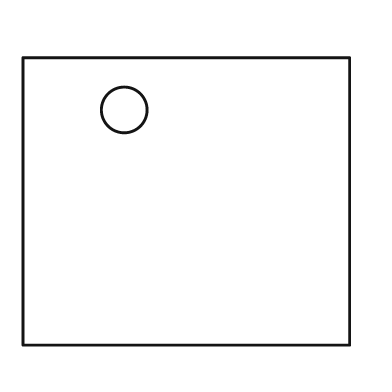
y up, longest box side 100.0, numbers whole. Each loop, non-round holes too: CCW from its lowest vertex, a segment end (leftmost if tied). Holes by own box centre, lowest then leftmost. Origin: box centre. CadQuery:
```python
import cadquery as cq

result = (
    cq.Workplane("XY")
    .moveTo(-50.0, -44.0)
    .lineTo(50.0, -44.0)
    .lineTo(50.0, 44.0)
    .lineTo(-50.0, 44.0)
    .close()
    .moveTo(-19.0, 28.0)
    .circle(7.0)
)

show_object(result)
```